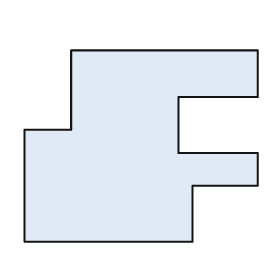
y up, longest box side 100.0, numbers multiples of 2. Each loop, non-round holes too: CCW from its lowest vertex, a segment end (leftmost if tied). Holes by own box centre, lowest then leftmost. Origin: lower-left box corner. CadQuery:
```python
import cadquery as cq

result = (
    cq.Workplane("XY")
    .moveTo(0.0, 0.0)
    .lineTo(72.0, 0.0)
    .lineTo(72.0, 24.0)
    .lineTo(100.0, 24.0)
    .lineTo(100.0, 38.0)
    .lineTo(66.0, 38.0)
    .lineTo(66.0, 62.0)
    .lineTo(100.0, 62.0)
    .lineTo(100.0, 82.0)
    .lineTo(20.0, 82.0)
    .lineTo(20.0, 48.0)
    .lineTo(0.0, 48.0)
    .close()
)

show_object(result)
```